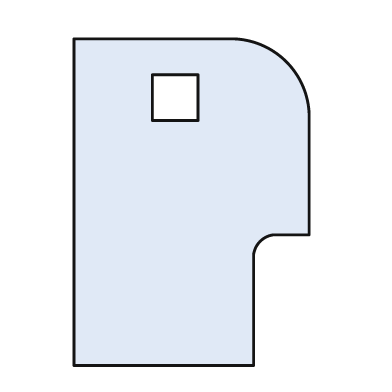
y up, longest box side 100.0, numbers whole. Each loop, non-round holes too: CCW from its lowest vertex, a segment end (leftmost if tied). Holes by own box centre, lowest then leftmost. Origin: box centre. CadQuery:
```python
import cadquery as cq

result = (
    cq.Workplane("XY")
    .moveTo(-36.0, -50.0)
    .lineTo(19.0, -50.0)
    .lineTo(19.0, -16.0)
    .threePointArc((21.0, -12.0), (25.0, -10.0))
    .lineTo(36.0, -10.0)
    .lineTo(36.0, 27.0)
    .threePointArc((29.0, 43.0), (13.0, 50.0))
    .lineTo(-36.0, 50.0)
    .close()
    .moveTo(-12.0, 25.0)
    .lineTo(2.0, 25.0)
    .lineTo(2.0, 39.0)
    .lineTo(-12.0, 39.0)
    .close()
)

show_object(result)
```